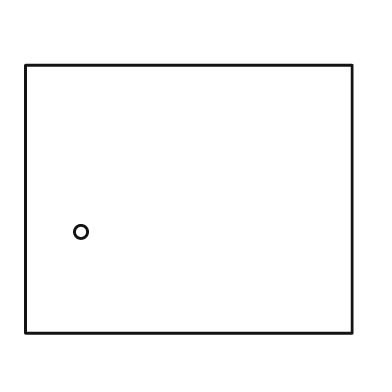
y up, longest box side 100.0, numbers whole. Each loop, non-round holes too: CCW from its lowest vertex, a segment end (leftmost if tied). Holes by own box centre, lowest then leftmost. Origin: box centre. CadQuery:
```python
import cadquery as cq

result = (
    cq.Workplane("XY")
    .moveTo(-50.0, -41.0)
    .lineTo(50.0, -41.0)
    .lineTo(50.0, 41.0)
    .lineTo(-50.0, 41.0)
    .close()
    .moveTo(-33.0, -10.0)
    .circle(2.0)
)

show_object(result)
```